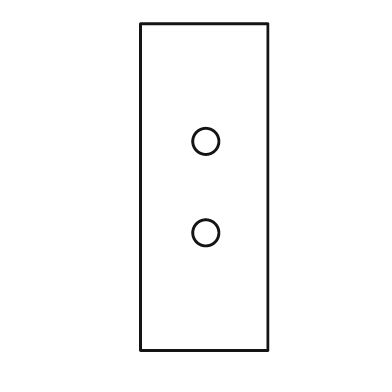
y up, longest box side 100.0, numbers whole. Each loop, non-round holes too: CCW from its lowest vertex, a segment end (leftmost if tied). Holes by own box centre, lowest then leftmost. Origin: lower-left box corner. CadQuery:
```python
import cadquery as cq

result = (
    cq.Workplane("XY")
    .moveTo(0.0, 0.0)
    .lineTo(39.0, 0.0)
    .lineTo(39.0, 100.0)
    .lineTo(0.0, 100.0)
    .close()
    .moveTo(20.0, 36.0)
    .circle(4.0)
    .moveTo(20.0, 64.0)
    .circle(4.0)
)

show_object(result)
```